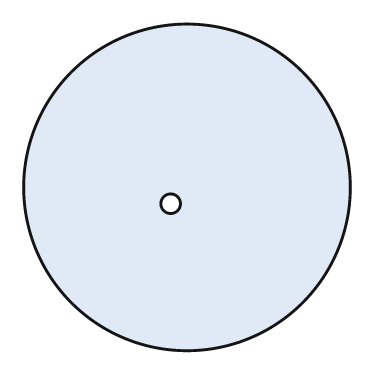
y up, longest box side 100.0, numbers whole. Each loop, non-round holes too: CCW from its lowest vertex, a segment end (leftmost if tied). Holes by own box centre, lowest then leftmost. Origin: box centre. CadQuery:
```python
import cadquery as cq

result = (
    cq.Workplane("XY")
    .moveTo(0.0, 0.0)
    .circle(50.0)
    .moveTo(-5.0, -5.0)
    .circle(3.0)
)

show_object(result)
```